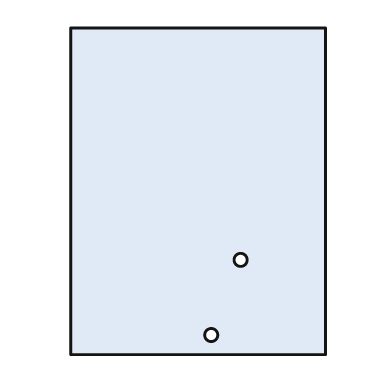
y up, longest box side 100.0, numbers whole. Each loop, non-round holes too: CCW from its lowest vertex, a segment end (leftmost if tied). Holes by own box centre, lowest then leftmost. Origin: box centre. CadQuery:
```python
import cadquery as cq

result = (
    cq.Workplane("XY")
    .moveTo(-39.0, -50.0)
    .lineTo(39.0, -50.0)
    .lineTo(39.0, 50.0)
    .lineTo(-39.0, 50.0)
    .close()
    .moveTo(4.0, -44.0)
    .circle(2.0)
    .moveTo(13.0, -21.0)
    .circle(2.0)
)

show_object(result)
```